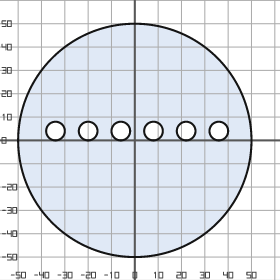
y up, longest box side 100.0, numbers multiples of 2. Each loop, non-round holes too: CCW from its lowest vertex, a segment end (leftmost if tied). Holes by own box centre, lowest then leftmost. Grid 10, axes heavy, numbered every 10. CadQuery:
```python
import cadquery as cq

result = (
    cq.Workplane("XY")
    .moveTo(0.0, 0.0)
    .circle(50.0)
    .moveTo(-34.0, 4.0)
    .circle(4.0)
    .moveTo(-20.0, 4.0)
    .circle(4.0)
    .moveTo(-6.0, 4.0)
    .circle(4.0)
    .moveTo(8.0, 4.0)
    .circle(4.0)
    .moveTo(22.0, 4.0)
    .circle(4.0)
    .moveTo(36.0, 4.0)
    .circle(4.0)
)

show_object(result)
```